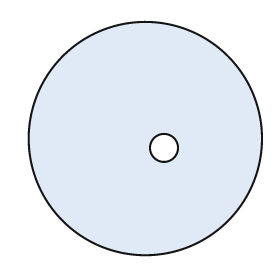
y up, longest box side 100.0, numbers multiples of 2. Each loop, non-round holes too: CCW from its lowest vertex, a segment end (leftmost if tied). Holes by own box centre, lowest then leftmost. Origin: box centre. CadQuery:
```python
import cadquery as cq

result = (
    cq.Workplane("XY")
    .moveTo(0.0, 0.0)
    .circle(50.0)
    .moveTo(8.0, -4.0)
    .circle(6.0)
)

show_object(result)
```